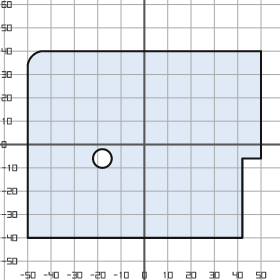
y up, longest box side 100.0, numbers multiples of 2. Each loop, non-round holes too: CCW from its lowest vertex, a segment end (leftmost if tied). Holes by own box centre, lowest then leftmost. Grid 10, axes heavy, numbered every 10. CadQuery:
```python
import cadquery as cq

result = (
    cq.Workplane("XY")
    .moveTo(-50.0, -40.0)
    .lineTo(42.0, -40.0)
    .lineTo(42.0, -6.0)
    .lineTo(50.0, -6.0)
    .lineTo(50.0, 40.0)
    .lineTo(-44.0, 40.0)
    .threePointArc((-48.0, 38.0), (-50.0, 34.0))
    .close()
    .moveTo(-18.0, -6.0)
    .circle(4.0)
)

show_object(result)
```